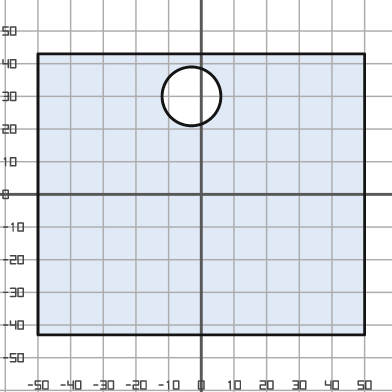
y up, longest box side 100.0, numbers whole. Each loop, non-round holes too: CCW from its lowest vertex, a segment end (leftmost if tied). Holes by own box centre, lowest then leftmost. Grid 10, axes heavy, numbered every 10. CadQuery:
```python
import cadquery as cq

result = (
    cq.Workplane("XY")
    .moveTo(-50.0, -43.0)
    .lineTo(50.0, -43.0)
    .lineTo(50.0, 43.0)
    .lineTo(-50.0, 43.0)
    .close()
    .moveTo(-3.0, 30.0)
    .circle(9.0)
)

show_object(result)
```